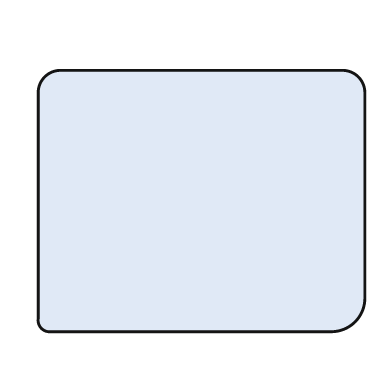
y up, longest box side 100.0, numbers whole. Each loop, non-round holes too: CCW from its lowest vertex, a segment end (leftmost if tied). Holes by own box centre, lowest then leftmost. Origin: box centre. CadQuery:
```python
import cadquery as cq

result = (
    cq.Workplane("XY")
    .moveTo(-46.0, -40.0)
    .lineTo(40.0, -40.0)
    .threePointArc((47.0, -37.0), (50.0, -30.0))
    .lineTo(50.0, 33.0)
    .threePointArc((48.0, 38.0), (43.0, 40.0))
    .lineTo(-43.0, 40.0)
    .threePointArc((-48.0, 38.0), (-50.0, 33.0))
    .lineTo(-50.0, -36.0)
    .threePointArc((-49.0, -39.0), (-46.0, -40.0))
    .close()
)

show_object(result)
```